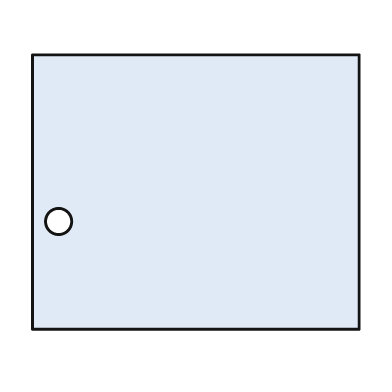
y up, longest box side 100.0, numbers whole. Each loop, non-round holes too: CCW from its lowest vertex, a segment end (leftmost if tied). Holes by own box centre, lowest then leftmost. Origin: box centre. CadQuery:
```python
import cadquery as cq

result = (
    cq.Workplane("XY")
    .moveTo(-50.0, -42.0)
    .lineTo(50.0, -42.0)
    .lineTo(50.0, 42.0)
    .lineTo(-50.0, 42.0)
    .close()
    .moveTo(-42.0, -9.0)
    .circle(4.0)
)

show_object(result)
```